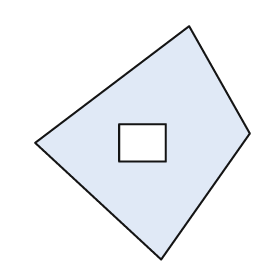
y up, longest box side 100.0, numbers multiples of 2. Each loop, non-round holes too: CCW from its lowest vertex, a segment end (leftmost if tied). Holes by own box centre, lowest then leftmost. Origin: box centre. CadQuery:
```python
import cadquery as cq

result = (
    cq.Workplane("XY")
    .moveTo(8.0, -50.0)
    .lineTo(46.0, 4.0)
    .lineTo(20.0, 50.0)
    .lineTo(-46.0, 0.0)
    .close()
    .moveTo(-10.0, -8.0)
    .lineTo(10.0, -8.0)
    .lineTo(10.0, 8.0)
    .lineTo(-10.0, 8.0)
    .close()
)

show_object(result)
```